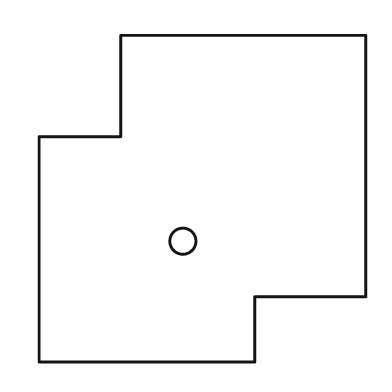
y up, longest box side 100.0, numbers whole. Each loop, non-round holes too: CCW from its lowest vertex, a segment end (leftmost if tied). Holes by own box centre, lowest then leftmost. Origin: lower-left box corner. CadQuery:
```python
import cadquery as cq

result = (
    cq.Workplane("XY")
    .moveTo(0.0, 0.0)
    .lineTo(66.0, 0.0)
    .lineTo(66.0, 20.0)
    .lineTo(100.0, 20.0)
    .lineTo(100.0, 100.0)
    .lineTo(25.0, 100.0)
    .lineTo(25.0, 69.0)
    .lineTo(0.0, 69.0)
    .close()
    .moveTo(44.0, 37.0)
    .circle(4.0)
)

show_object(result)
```